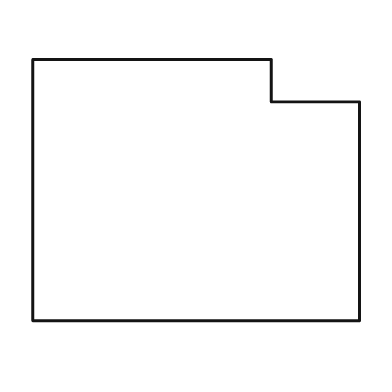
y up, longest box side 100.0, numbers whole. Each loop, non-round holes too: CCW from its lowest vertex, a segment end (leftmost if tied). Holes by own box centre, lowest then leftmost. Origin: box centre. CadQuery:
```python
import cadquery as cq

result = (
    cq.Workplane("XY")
    .moveTo(-50.0, -40.0)
    .lineTo(50.0, -40.0)
    .lineTo(50.0, 27.0)
    .lineTo(23.0, 27.0)
    .lineTo(23.0, 40.0)
    .lineTo(-50.0, 40.0)
    .close()
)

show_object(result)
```